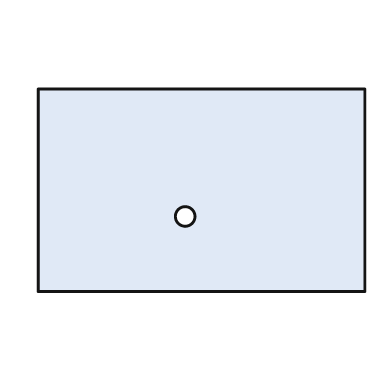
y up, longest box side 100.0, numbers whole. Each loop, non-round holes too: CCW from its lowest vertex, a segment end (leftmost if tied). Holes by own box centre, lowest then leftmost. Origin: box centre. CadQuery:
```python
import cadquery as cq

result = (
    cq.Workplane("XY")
    .moveTo(-50.0, -31.0)
    .lineTo(50.0, -31.0)
    .lineTo(50.0, 31.0)
    .lineTo(-50.0, 31.0)
    .close()
    .moveTo(-5.0, -8.0)
    .circle(3.0)
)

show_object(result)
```